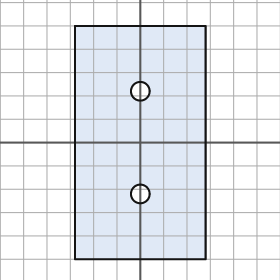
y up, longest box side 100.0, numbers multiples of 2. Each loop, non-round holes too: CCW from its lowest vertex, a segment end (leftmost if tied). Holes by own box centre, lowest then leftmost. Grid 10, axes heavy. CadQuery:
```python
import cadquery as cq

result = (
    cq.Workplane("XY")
    .moveTo(-28.0, -50.0)
    .lineTo(28.0, -50.0)
    .lineTo(28.0, 50.0)
    .lineTo(-28.0, 50.0)
    .close()
    .moveTo(0.0, -22.0)
    .circle(4.0)
    .moveTo(0.0, 22.0)
    .circle(4.0)
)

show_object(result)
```